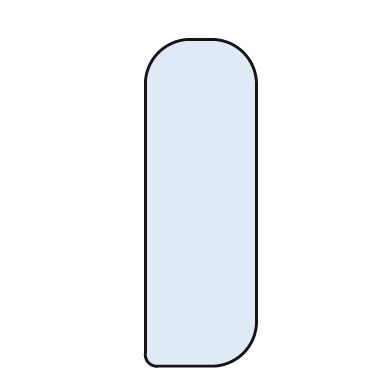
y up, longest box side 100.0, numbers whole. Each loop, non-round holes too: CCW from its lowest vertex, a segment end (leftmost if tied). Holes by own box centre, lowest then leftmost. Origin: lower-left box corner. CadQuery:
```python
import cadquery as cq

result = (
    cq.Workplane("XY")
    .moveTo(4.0, 0.0)
    .lineTo(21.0, 0.0)
    .threePointArc((30.0, 4.0), (34.0, 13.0))
    .lineTo(34.0, 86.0)
    .threePointArc((30.0, 96.0), (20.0, 100.0))
    .lineTo(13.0, 100.0)
    .threePointArc((4.0, 96.0), (0.0, 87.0))
    .lineTo(0.0, 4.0)
    .threePointArc((1.0, 1.0), (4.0, 0.0))
    .close()
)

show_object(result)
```